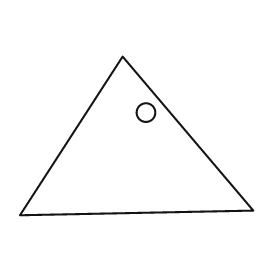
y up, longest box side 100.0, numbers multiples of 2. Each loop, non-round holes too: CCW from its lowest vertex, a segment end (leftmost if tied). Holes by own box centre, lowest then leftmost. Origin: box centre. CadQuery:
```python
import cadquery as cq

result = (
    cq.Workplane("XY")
    .moveTo(-50.0, -34.0)
    .lineTo(50.0, -32.0)
    .lineTo(-6.0, 34.0)
    .close()
    .moveTo(4.0, 10.0)
    .circle(4.0)
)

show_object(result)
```